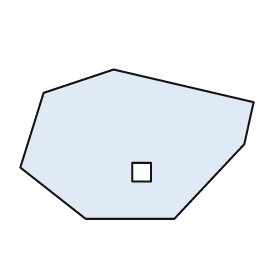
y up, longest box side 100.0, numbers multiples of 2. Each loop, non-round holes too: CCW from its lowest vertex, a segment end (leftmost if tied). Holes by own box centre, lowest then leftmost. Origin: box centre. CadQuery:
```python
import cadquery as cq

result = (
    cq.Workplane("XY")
    .moveTo(-22.0, -32.0)
    .lineTo(16.0, -32.0)
    .lineTo(46.0, 0.0)
    .lineTo(50.0, 18.0)
    .lineTo(-10.0, 32.0)
    .lineTo(-40.0, 22.0)
    .lineTo(-50.0, -10.0)
    .close()
    .moveTo(-2.0, -16.0)
    .lineTo(6.0, -16.0)
    .lineTo(6.0, -8.0)
    .lineTo(-2.0, -8.0)
    .close()
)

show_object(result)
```